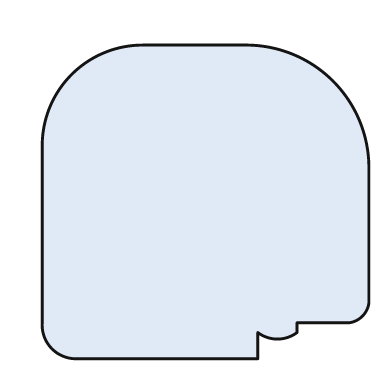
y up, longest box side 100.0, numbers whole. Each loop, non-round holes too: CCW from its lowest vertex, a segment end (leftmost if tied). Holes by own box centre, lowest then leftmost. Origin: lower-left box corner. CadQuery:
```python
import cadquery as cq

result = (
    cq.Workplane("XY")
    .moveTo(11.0, 0.0)
    .lineTo(66.0, 0.0)
    .lineTo(66.0, 8.0)
    .threePointArc((72.0, 6.0), (78.0, 8.0))
    .lineTo(78.0, 11.0)
    .lineTo(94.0, 11.0)
    .threePointArc((98.0, 13.0), (100.0, 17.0))
    .lineTo(100.0, 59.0)
    .threePointArc((89.0, 85.0), (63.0, 96.0))
    .lineTo(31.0, 96.0)
    .threePointArc((9.0, 87.0), (0.0, 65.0))
    .lineTo(0.0, 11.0)
    .threePointArc((3.0, 3.0), (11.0, 0.0))
    .close()
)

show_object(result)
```